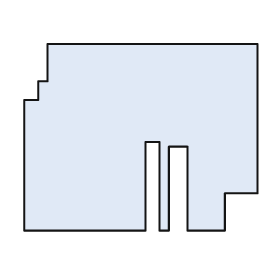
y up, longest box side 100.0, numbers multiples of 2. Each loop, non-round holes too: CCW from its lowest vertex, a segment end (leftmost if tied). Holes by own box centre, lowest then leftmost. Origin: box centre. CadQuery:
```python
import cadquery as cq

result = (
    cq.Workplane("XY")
    .moveTo(-50.0, -40.0)
    .lineTo(2.0, -40.0)
    .lineTo(2.0, -2.0)
    .lineTo(8.0, -2.0)
    .lineTo(8.0, -40.0)
    .lineTo(12.0, -40.0)
    .lineTo(12.0, -4.0)
    .lineTo(20.0, -4.0)
    .lineTo(20.0, -40.0)
    .lineTo(36.0, -40.0)
    .lineTo(36.0, -24.0)
    .lineTo(50.0, -24.0)
    .lineTo(50.0, 40.0)
    .lineTo(-40.0, 40.0)
    .lineTo(-40.0, 24.0)
    .lineTo(-44.0, 24.0)
    .lineTo(-44.0, 16.0)
    .lineTo(-50.0, 16.0)
    .close()
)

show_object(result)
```